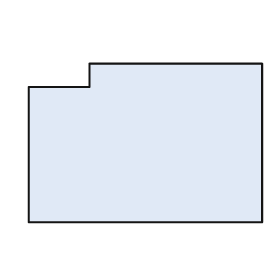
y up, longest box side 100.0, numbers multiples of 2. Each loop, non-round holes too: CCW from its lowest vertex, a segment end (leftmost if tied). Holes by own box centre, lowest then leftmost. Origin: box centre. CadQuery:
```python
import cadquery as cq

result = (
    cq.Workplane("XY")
    .moveTo(-50.0, -34.0)
    .lineTo(50.0, -34.0)
    .lineTo(50.0, 34.0)
    .lineTo(-24.0, 34.0)
    .lineTo(-24.0, 24.0)
    .lineTo(-50.0, 24.0)
    .close()
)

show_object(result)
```